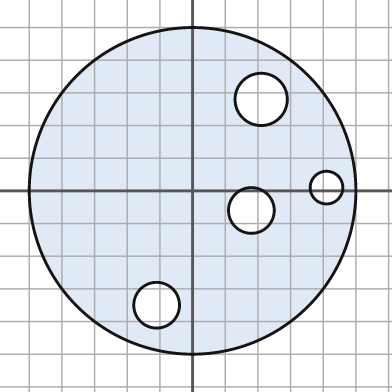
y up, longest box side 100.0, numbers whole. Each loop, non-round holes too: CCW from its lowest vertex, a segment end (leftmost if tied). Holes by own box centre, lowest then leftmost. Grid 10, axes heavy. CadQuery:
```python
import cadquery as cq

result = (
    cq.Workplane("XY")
    .moveTo(0.0, 0.0)
    .circle(50.0)
    .moveTo(-11.0, -35.0)
    .circle(7.0)
    .moveTo(18.0, -6.0)
    .circle(7.0)
    .moveTo(41.0, 1.0)
    .circle(5.0)
    .moveTo(21.0, 28.0)
    .circle(8.0)
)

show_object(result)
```